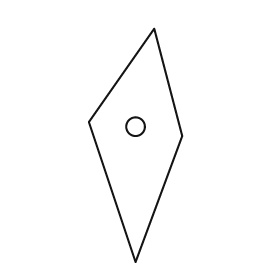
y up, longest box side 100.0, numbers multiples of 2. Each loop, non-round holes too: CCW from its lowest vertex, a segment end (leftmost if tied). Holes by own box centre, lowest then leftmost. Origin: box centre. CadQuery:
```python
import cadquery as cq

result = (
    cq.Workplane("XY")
    .moveTo(0.0, -50.0)
    .lineTo(20.0, 4.0)
    .lineTo(8.0, 50.0)
    .lineTo(-20.0, 10.0)
    .close()
    .moveTo(0.0, 8.0)
    .circle(4.0)
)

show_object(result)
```